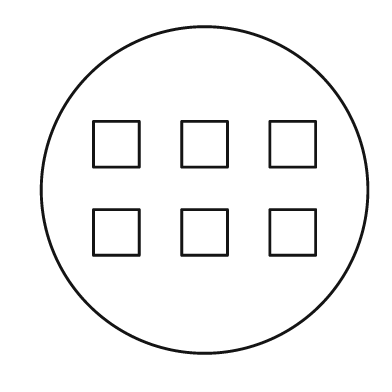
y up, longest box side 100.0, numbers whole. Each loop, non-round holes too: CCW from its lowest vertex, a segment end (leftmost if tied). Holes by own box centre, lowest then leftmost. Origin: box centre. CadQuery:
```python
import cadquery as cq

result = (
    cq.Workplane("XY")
    .moveTo(0.0, 0.0)
    .circle(50.0)
    .moveTo(-34.0, -20.0)
    .lineTo(-20.0, -20.0)
    .lineTo(-20.0, -6.0)
    .lineTo(-34.0, -6.0)
    .close()
    .moveTo(-7.0, -20.0)
    .lineTo(7.0, -20.0)
    .lineTo(7.0, -6.0)
    .lineTo(-7.0, -6.0)
    .close()
    .moveTo(20.0, -20.0)
    .lineTo(34.0, -20.0)
    .lineTo(34.0, -6.0)
    .lineTo(20.0, -6.0)
    .close()
    .moveTo(-34.0, 7.0)
    .lineTo(-20.0, 7.0)
    .lineTo(-20.0, 21.0)
    .lineTo(-34.0, 21.0)
    .close()
    .moveTo(-7.0, 7.0)
    .lineTo(7.0, 7.0)
    .lineTo(7.0, 21.0)
    .lineTo(-7.0, 21.0)
    .close()
    .moveTo(20.0, 7.0)
    .lineTo(34.0, 7.0)
    .lineTo(34.0, 21.0)
    .lineTo(20.0, 21.0)
    .close()
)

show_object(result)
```